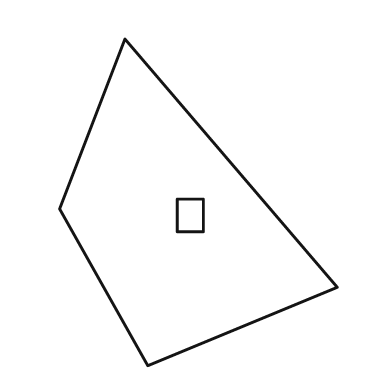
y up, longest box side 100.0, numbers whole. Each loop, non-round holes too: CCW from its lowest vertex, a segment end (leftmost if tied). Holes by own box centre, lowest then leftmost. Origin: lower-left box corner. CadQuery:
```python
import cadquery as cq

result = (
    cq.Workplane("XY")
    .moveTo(27.0, 0.0)
    .lineTo(85.0, 24.0)
    .lineTo(20.0, 100.0)
    .lineTo(0.0, 48.0)
    .close()
    .moveTo(36.0, 41.0)
    .lineTo(44.0, 41.0)
    .lineTo(44.0, 51.0)
    .lineTo(36.0, 51.0)
    .close()
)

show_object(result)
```